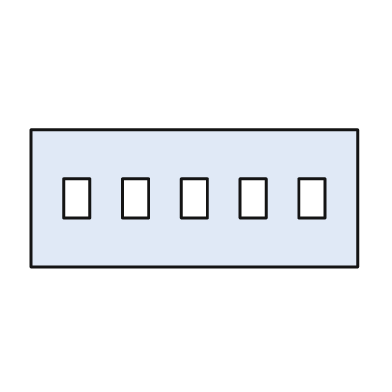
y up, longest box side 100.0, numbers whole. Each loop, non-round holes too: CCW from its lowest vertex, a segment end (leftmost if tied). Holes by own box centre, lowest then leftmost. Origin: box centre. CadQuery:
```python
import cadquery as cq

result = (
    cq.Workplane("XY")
    .moveTo(-50.0, -21.0)
    .lineTo(50.0, -21.0)
    .lineTo(50.0, 21.0)
    .lineTo(-50.0, 21.0)
    .close()
    .moveTo(-40.0, -6.0)
    .lineTo(-32.0, -6.0)
    .lineTo(-32.0, 6.0)
    .lineTo(-40.0, 6.0)
    .close()
    .moveTo(-22.0, -6.0)
    .lineTo(-14.0, -6.0)
    .lineTo(-14.0, 6.0)
    .lineTo(-22.0, 6.0)
    .close()
    .moveTo(-4.0, -6.0)
    .lineTo(4.0, -6.0)
    .lineTo(4.0, 6.0)
    .lineTo(-4.0, 6.0)
    .close()
    .moveTo(14.0, -6.0)
    .lineTo(22.0, -6.0)
    .lineTo(22.0, 6.0)
    .lineTo(14.0, 6.0)
    .close()
    .moveTo(32.0, -6.0)
    .lineTo(40.0, -6.0)
    .lineTo(40.0, 6.0)
    .lineTo(32.0, 6.0)
    .close()
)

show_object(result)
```